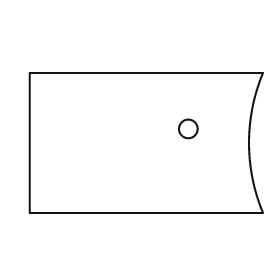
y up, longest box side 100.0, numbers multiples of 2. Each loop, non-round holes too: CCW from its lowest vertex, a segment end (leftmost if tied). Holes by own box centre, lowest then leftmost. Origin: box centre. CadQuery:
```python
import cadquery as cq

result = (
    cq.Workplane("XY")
    .moveTo(-50.0, -30.0)
    .lineTo(50.0, -30.0)
    .threePointArc((44.0, 0.0), (50.0, 30.0))
    .lineTo(-50.0, 30.0)
    .close()
    .moveTo(18.0, 6.0)
    .circle(4.0)
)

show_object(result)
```